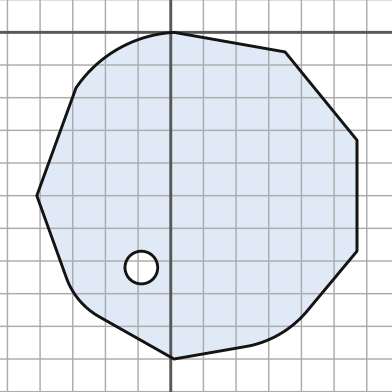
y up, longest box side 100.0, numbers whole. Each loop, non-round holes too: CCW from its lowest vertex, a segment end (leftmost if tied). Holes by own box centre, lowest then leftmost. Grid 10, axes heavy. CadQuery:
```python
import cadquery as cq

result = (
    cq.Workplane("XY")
    .moveTo(1.0, -100.0)
    .lineTo(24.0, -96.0)
    .threePointArc((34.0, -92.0), (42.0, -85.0))
    .lineTo(57.0, -67.0)
    .lineTo(57.0, -33.0)
    .lineTo(35.0, -6.0)
    .lineTo(1.0, 0.0)
    .threePointArc((-16.0, -5.0), (-29.0, -17.0))
    .lineTo(-41.0, -50.0)
    .lineTo(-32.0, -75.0)
    .threePointArc((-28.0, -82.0), (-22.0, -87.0))
    .close()
    .moveTo(-9.0, -72.0)
    .circle(5.0)
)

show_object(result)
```